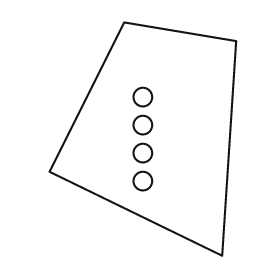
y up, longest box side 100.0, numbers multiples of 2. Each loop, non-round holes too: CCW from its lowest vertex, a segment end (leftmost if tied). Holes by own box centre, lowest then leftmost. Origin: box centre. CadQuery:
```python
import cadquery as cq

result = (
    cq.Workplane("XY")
    .moveTo(34.0, -50.0)
    .lineTo(40.0, 42.0)
    .lineTo(-8.0, 50.0)
    .lineTo(-40.0, -14.0)
    .close()
    .moveTo(0.0, -18.0)
    .circle(4.0)
    .moveTo(0.0, -6.0)
    .circle(4.0)
    .moveTo(0.0, 6.0)
    .circle(4.0)
    .moveTo(0.0, 18.0)
    .circle(4.0)
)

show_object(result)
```